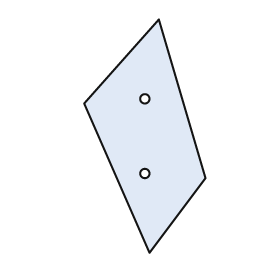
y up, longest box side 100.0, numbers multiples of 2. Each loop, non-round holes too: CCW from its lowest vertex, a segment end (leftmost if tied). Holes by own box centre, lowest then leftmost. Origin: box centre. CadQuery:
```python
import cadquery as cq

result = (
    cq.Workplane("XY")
    .moveTo(2.0, -50.0)
    .lineTo(26.0, -18.0)
    .lineTo(6.0, 50.0)
    .lineTo(-26.0, 14.0)
    .close()
    .moveTo(0.0, -16.0)
    .circle(2.0)
    .moveTo(0.0, 16.0)
    .circle(2.0)
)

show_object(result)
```